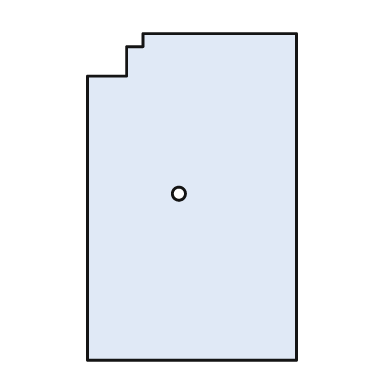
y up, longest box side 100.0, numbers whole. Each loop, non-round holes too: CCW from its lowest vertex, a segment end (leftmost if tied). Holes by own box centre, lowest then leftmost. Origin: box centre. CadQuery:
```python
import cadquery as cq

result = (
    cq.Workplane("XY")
    .moveTo(-32.0, -50.0)
    .lineTo(32.0, -50.0)
    .lineTo(32.0, 50.0)
    .lineTo(-15.0, 50.0)
    .lineTo(-15.0, 46.0)
    .lineTo(-20.0, 46.0)
    .lineTo(-20.0, 37.0)
    .lineTo(-32.0, 37.0)
    .close()
    .moveTo(-4.0, 1.0)
    .circle(2.0)
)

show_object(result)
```